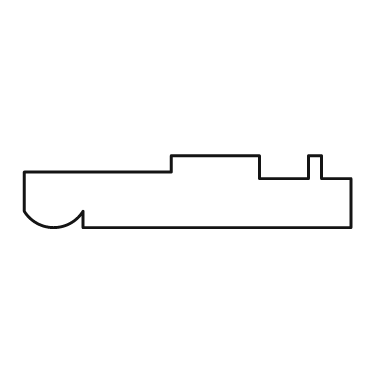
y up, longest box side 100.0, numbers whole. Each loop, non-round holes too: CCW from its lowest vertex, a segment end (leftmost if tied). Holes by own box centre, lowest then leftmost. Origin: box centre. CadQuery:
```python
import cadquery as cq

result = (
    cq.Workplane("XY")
    .moveTo(-32.0, -11.0)
    .lineTo(50.0, -11.0)
    .lineTo(50.0, 4.0)
    .lineTo(41.0, 4.0)
    .lineTo(41.0, 11.0)
    .lineTo(37.0, 11.0)
    .lineTo(37.0, 4.0)
    .lineTo(22.0, 4.0)
    .lineTo(22.0, 11.0)
    .lineTo(-5.0, 11.0)
    .lineTo(-5.0, 6.0)
    .lineTo(-50.0, 6.0)
    .lineTo(-50.0, -6.0)
    .threePointArc((-41.0, -11.0), (-32.0, -6.0))
    .close()
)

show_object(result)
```